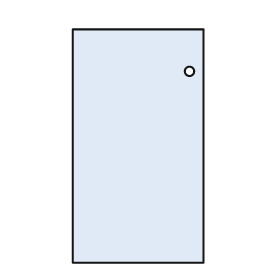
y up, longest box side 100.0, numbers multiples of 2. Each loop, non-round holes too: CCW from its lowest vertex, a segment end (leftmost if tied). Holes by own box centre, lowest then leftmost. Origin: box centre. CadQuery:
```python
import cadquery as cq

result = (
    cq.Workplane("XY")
    .moveTo(-28.0, -50.0)
    .lineTo(28.0, -50.0)
    .lineTo(28.0, 50.0)
    .lineTo(-28.0, 50.0)
    .close()
    .moveTo(22.0, 32.0)
    .circle(2.0)
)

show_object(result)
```